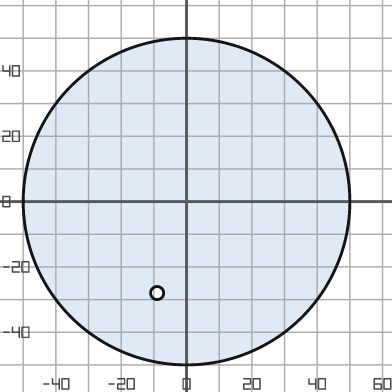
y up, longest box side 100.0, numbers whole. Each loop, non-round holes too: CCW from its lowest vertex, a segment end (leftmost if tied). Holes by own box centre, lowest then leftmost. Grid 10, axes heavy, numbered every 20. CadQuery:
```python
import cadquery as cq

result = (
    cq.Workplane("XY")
    .moveTo(0.0, 0.0)
    .circle(50.0)
    .moveTo(-9.0, -28.0)
    .circle(2.0)
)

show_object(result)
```